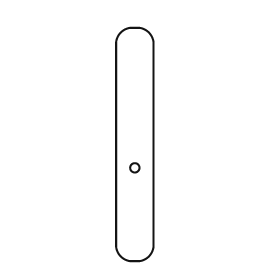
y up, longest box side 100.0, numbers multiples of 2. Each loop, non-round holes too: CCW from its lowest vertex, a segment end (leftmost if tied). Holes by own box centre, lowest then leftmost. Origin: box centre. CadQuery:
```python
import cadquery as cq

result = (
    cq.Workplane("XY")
    .moveTo(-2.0, -50.0)
    .lineTo(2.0, -50.0)
    .threePointArc((6.0, -48.0), (8.0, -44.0))
    .lineTo(8.0, 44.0)
    .threePointArc((6.0, 48.0), (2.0, 50.0))
    .lineTo(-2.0, 50.0)
    .threePointArc((-6.0, 48.0), (-8.0, 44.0))
    .lineTo(-8.0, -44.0)
    .threePointArc((-6.0, -48.0), (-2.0, -50.0))
    .close()
    .moveTo(0.0, -10.0)
    .circle(2.0)
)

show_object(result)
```